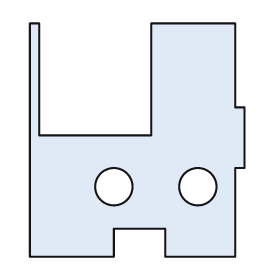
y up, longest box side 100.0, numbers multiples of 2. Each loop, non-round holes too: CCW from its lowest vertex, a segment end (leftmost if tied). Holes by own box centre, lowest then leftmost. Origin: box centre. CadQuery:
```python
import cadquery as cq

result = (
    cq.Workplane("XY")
    .moveTo(-46.0, -50.0)
    .lineTo(-10.0, -50.0)
    .lineTo(-10.0, -38.0)
    .lineTo(12.0, -38.0)
    .lineTo(12.0, -50.0)
    .lineTo(42.0, -50.0)
    .lineTo(42.0, -12.0)
    .lineTo(46.0, -12.0)
    .lineTo(46.0, 14.0)
    .lineTo(42.0, 14.0)
    .lineTo(42.0, 50.0)
    .lineTo(6.0, 50.0)
    .lineTo(6.0, 2.0)
    .lineTo(-42.0, 2.0)
    .lineTo(-42.0, 50.0)
    .lineTo(-46.0, 50.0)
    .close()
    .moveTo(-10.0, -20.0)
    .circle(8.0)
    .moveTo(26.0, -20.0)
    .circle(8.0)
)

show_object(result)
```